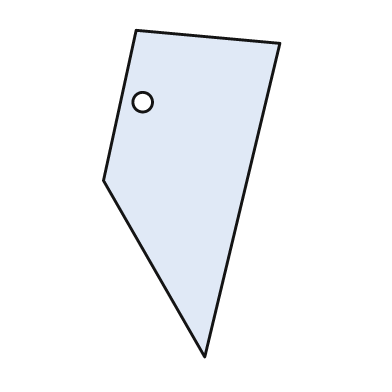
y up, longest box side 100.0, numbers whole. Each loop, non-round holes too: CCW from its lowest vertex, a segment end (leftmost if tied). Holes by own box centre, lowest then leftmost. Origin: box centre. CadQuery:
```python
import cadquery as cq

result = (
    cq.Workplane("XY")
    .moveTo(4.0, -50.0)
    .lineTo(27.0, 46.0)
    .lineTo(-17.0, 50.0)
    .lineTo(-27.0, 4.0)
    .close()
    .moveTo(-15.0, 28.0)
    .circle(3.0)
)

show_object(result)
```